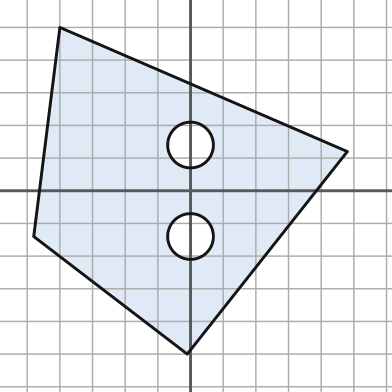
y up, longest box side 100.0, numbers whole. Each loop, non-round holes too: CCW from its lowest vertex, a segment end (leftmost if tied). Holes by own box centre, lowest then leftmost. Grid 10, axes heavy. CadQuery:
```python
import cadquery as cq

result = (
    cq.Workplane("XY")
    .moveTo(-1.0, -50.0)
    .lineTo(48.0, 12.0)
    .lineTo(-40.0, 50.0)
    .lineTo(-48.0, -14.0)
    .close()
    .moveTo(0.0, -14.0)
    .circle(7.0)
    .moveTo(0.0, 14.0)
    .circle(7.0)
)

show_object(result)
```